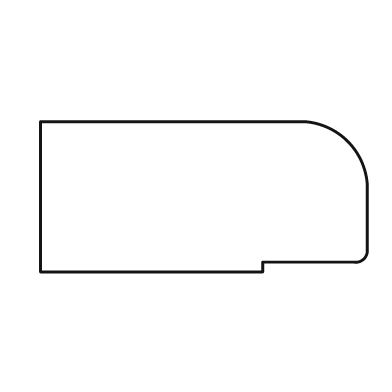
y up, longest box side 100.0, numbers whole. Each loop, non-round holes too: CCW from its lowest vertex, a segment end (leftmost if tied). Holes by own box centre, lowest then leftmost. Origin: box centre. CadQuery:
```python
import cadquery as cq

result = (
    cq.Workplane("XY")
    .moveTo(-50.0, -23.0)
    .lineTo(18.0, -23.0)
    .lineTo(18.0, -20.0)
    .lineTo(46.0, -20.0)
    .threePointArc((49.0, -19.0), (50.0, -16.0))
    .lineTo(50.0, 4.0)
    .threePointArc((44.0, 17.0), (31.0, 23.0))
    .lineTo(-50.0, 23.0)
    .close()
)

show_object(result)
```